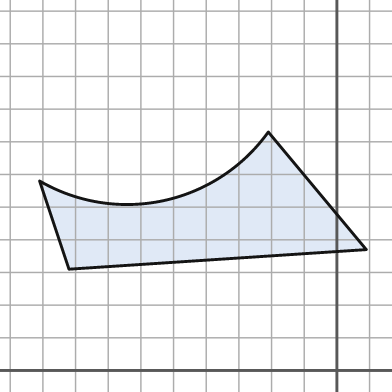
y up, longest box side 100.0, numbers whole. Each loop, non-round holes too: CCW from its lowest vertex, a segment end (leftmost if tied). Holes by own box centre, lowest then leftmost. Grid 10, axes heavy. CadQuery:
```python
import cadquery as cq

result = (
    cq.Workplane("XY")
    .moveTo(-82.0, 31.0)
    .lineTo(9.0, 37.0)
    .lineTo(-21.0, 73.0)
    .threePointArc((-53.0, 52.0), (-91.0, 58.0))
    .close()
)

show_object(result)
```